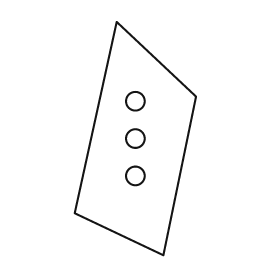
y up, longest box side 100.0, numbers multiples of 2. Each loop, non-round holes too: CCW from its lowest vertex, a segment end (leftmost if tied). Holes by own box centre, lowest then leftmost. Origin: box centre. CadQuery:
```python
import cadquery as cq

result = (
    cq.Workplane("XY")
    .moveTo(12.0, -50.0)
    .lineTo(26.0, 18.0)
    .lineTo(-8.0, 50.0)
    .lineTo(-26.0, -32.0)
    .close()
    .moveTo(0.0, -16.0)
    .circle(4.0)
    .moveTo(0.0, 0.0)
    .circle(4.0)
    .moveTo(0.0, 16.0)
    .circle(4.0)
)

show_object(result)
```